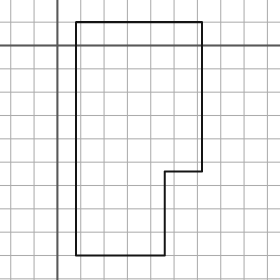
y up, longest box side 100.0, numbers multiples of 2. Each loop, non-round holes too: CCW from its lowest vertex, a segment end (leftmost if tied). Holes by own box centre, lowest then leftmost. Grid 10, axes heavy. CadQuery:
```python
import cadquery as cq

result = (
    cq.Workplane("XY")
    .moveTo(8.0, -90.0)
    .lineTo(46.0, -90.0)
    .lineTo(46.0, -54.0)
    .lineTo(62.0, -54.0)
    .lineTo(62.0, 10.0)
    .lineTo(8.0, 10.0)
    .close()
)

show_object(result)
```